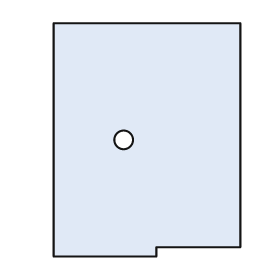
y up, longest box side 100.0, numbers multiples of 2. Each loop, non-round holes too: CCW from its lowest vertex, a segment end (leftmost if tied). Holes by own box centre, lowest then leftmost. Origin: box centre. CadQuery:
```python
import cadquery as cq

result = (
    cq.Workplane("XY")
    .moveTo(-40.0, -50.0)
    .lineTo(4.0, -50.0)
    .lineTo(4.0, -46.0)
    .lineTo(40.0, -46.0)
    .lineTo(40.0, 50.0)
    .lineTo(-40.0, 50.0)
    .close()
    .moveTo(-10.0, 0.0)
    .circle(4.0)
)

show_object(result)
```